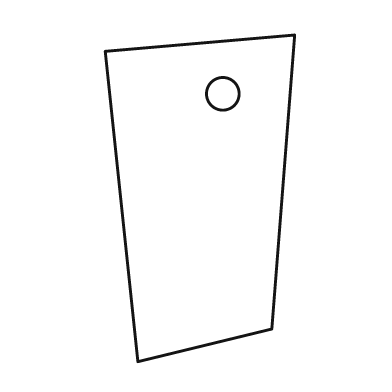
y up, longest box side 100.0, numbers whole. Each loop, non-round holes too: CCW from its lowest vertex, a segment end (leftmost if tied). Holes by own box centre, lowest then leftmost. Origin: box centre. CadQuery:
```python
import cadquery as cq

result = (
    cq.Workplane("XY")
    .moveTo(-19.0, -50.0)
    .lineTo(22.0, -40.0)
    .lineTo(29.0, 50.0)
    .lineTo(-29.0, 45.0)
    .close()
    .moveTo(7.0, 32.0)
    .circle(5.0)
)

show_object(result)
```